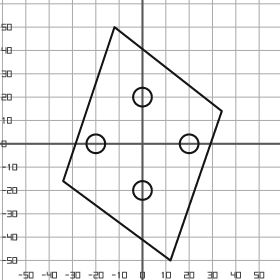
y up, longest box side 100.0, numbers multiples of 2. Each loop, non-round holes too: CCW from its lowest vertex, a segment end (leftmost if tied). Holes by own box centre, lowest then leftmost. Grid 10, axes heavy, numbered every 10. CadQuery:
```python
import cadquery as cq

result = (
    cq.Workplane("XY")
    .moveTo(12.0, -50.0)
    .lineTo(34.0, 14.0)
    .lineTo(-12.0, 50.0)
    .lineTo(-34.0, -16.0)
    .close()
    .moveTo(0.0, -20.0)
    .circle(4.0)
    .moveTo(-20.0, 0.0)
    .circle(4.0)
    .moveTo(20.0, 0.0)
    .circle(4.0)
    .moveTo(0.0, 20.0)
    .circle(4.0)
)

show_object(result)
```